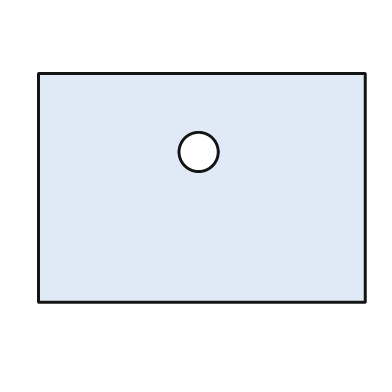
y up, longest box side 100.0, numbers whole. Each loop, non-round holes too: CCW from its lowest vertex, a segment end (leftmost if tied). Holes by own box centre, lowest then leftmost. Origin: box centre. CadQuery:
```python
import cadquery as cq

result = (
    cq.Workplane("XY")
    .moveTo(-50.0, -35.0)
    .lineTo(50.0, -35.0)
    .lineTo(50.0, 35.0)
    .lineTo(-50.0, 35.0)
    .close()
    .moveTo(-1.0, 11.0)
    .circle(6.0)
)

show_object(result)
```